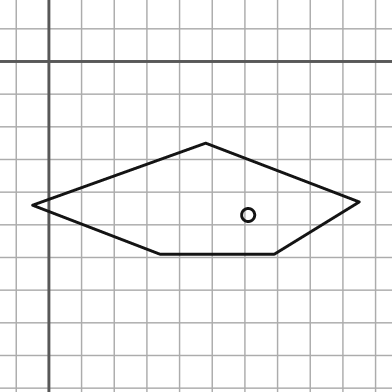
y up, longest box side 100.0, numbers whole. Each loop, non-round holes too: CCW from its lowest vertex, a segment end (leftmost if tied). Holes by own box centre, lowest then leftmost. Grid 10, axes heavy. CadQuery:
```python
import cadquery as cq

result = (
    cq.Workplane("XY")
    .moveTo(34.0, -59.0)
    .lineTo(69.0, -59.0)
    .lineTo(95.0, -43.0)
    .lineTo(48.0, -25.0)
    .lineTo(-5.0, -44.0)
    .close()
    .moveTo(61.0, -47.0)
    .circle(2.0)
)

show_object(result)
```